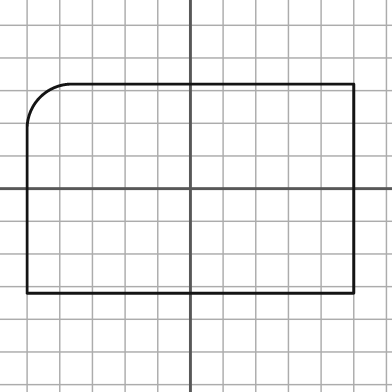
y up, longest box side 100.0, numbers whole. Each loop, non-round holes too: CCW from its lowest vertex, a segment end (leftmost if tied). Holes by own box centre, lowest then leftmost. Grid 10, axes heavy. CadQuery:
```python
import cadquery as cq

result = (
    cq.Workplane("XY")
    .moveTo(-50.0, -32.0)
    .lineTo(50.0, -32.0)
    .lineTo(50.0, 32.0)
    .lineTo(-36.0, 32.0)
    .threePointArc((-46.0, 28.0), (-50.0, 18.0))
    .close()
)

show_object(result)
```